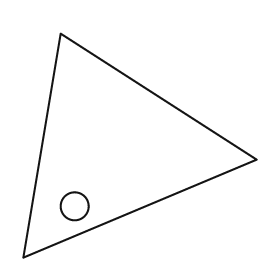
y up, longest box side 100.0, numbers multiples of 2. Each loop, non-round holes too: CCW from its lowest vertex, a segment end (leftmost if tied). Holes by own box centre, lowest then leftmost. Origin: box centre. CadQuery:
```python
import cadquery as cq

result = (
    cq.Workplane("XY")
    .moveTo(-50.0, -48.0)
    .lineTo(50.0, -6.0)
    .lineTo(-34.0, 48.0)
    .close()
    .moveTo(-28.0, -26.0)
    .circle(6.0)
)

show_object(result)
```